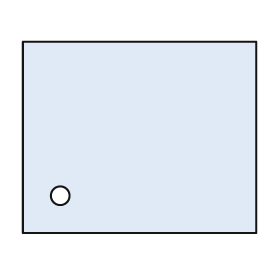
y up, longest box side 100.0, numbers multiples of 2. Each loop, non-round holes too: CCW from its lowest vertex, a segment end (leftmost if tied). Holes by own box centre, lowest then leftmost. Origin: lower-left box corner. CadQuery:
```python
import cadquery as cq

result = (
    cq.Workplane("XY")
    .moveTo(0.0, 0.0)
    .lineTo(100.0, 0.0)
    .lineTo(100.0, 82.0)
    .lineTo(0.0, 82.0)
    .close()
    .moveTo(16.0, 16.0)
    .circle(4.0)
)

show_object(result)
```